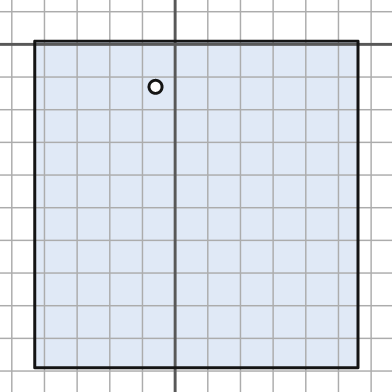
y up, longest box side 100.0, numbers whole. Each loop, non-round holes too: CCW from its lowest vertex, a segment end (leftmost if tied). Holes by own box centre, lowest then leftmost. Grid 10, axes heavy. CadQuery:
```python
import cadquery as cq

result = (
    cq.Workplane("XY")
    .moveTo(-43.0, -99.0)
    .lineTo(56.0, -99.0)
    .lineTo(56.0, 1.0)
    .lineTo(-43.0, 1.0)
    .close()
    .moveTo(-6.0, -13.0)
    .circle(2.0)
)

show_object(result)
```